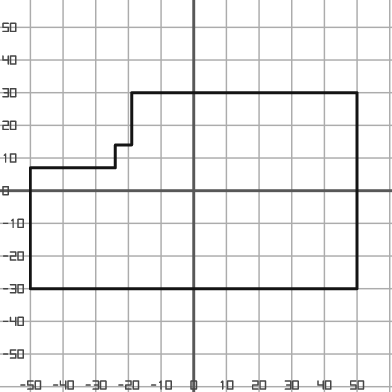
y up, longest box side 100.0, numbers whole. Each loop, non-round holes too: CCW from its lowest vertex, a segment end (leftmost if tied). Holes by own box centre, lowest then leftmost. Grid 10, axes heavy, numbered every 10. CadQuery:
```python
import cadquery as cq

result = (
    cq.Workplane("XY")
    .moveTo(-50.0, -30.0)
    .lineTo(50.0, -30.0)
    .lineTo(50.0, 30.0)
    .lineTo(-19.0, 30.0)
    .lineTo(-19.0, 14.0)
    .lineTo(-24.0, 14.0)
    .lineTo(-24.0, 7.0)
    .lineTo(-50.0, 7.0)
    .close()
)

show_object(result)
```